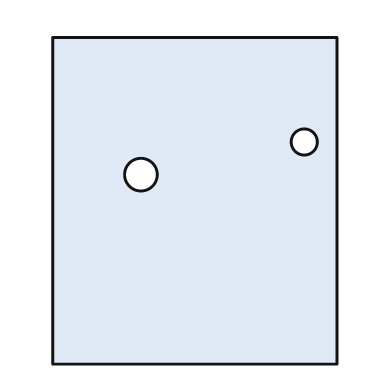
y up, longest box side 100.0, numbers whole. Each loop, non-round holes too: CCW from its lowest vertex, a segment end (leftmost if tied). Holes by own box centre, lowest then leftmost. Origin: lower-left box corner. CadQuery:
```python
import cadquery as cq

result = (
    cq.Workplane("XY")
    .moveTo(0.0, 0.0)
    .lineTo(87.0, 0.0)
    .lineTo(87.0, 100.0)
    .lineTo(0.0, 100.0)
    .close()
    .moveTo(27.0, 58.0)
    .circle(5.0)
    .moveTo(77.0, 68.0)
    .circle(4.0)
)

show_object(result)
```